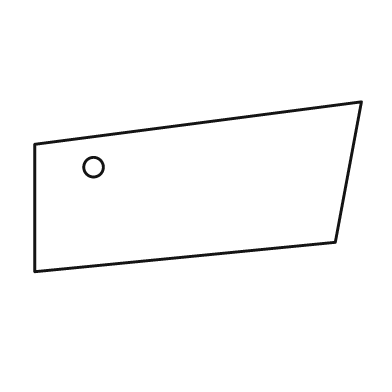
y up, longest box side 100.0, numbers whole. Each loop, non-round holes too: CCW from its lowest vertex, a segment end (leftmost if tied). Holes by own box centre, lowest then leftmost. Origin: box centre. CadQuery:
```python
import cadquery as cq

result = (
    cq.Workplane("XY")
    .moveTo(-50.0, -26.0)
    .lineTo(42.0, -17.0)
    .lineTo(50.0, 26.0)
    .lineTo(-50.0, 13.0)
    .close()
    .moveTo(-32.0, 6.0)
    .circle(3.0)
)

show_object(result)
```